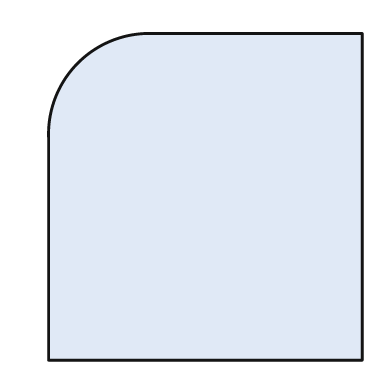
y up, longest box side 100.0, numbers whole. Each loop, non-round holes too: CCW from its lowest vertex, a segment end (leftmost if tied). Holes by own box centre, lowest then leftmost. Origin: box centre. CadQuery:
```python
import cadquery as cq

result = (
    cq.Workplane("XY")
    .moveTo(-48.0, -50.0)
    .lineTo(48.0, -50.0)
    .lineTo(48.0, 50.0)
    .lineTo(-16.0, 50.0)
    .threePointArc((-39.0, 41.0), (-48.0, 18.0))
    .close()
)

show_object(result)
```